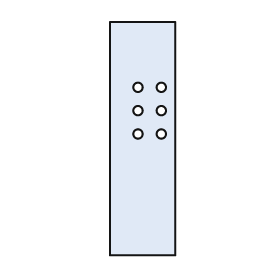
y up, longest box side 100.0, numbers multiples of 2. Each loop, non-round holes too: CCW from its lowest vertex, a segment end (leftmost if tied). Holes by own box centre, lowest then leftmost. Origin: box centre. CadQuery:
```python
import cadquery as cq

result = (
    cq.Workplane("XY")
    .moveTo(-14.0, -50.0)
    .lineTo(14.0, -50.0)
    .lineTo(14.0, 50.0)
    .lineTo(-14.0, 50.0)
    .close()
    .moveTo(-2.0, 2.0)
    .circle(2.0)
    .moveTo(8.0, 2.0)
    .circle(2.0)
    .moveTo(-2.0, 12.0)
    .circle(2.0)
    .moveTo(8.0, 12.0)
    .circle(2.0)
    .moveTo(-2.0, 22.0)
    .circle(2.0)
    .moveTo(8.0, 22.0)
    .circle(2.0)
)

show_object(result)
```